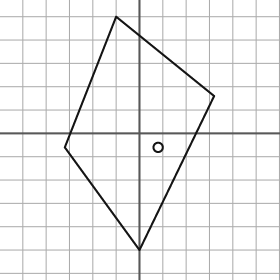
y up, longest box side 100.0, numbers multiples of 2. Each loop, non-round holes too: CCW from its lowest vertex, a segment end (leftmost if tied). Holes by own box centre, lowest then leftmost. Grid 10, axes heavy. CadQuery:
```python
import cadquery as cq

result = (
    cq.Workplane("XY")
    .moveTo(0.0, -50.0)
    .lineTo(32.0, 16.0)
    .lineTo(-10.0, 50.0)
    .lineTo(-32.0, -6.0)
    .close()
    .moveTo(8.0, -6.0)
    .circle(2.0)
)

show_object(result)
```